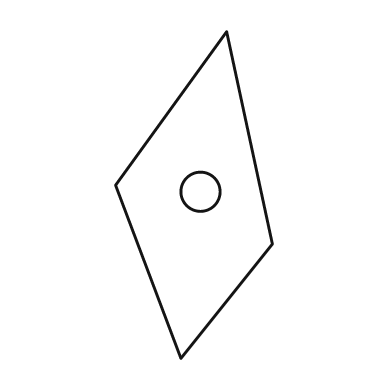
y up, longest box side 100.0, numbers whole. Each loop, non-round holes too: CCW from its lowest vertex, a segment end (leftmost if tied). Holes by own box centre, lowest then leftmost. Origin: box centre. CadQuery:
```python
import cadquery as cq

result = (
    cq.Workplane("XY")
    .moveTo(-4.0, -50.0)
    .lineTo(24.0, -15.0)
    .lineTo(10.0, 50.0)
    .lineTo(-24.0, 3.0)
    .close()
    .moveTo(2.0, 1.0)
    .circle(6.0)
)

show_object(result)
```